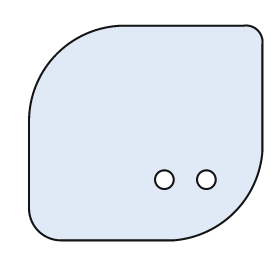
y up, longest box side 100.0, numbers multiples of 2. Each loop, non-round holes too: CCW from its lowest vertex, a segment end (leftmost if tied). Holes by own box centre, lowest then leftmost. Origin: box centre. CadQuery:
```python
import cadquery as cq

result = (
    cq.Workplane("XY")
    .moveTo(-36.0, -46.0)
    .lineTo(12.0, -46.0)
    .threePointArc((38.0, -34.0), (50.0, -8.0))
    .lineTo(50.0, 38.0)
    .threePointArc((48.0, 44.0), (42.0, 46.0))
    .lineTo(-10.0, 46.0)
    .threePointArc((-38.0, 34.0), (-50.0, 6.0))
    .lineTo(-50.0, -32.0)
    .threePointArc((-46.0, -42.0), (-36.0, -46.0))
    .close()
    .moveTo(8.0, -20.0)
    .circle(4.0)
    .moveTo(26.0, -20.0)
    .circle(4.0)
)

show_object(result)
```